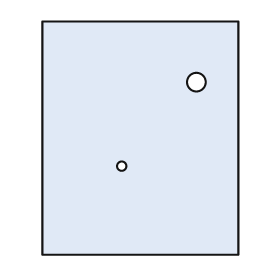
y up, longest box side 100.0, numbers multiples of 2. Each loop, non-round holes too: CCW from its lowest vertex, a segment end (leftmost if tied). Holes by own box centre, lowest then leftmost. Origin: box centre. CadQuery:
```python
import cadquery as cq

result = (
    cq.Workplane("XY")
    .moveTo(-42.0, -50.0)
    .lineTo(42.0, -50.0)
    .lineTo(42.0, 50.0)
    .lineTo(-42.0, 50.0)
    .close()
    .moveTo(-8.0, -12.0)
    .circle(2.0)
    .moveTo(24.0, 24.0)
    .circle(4.0)
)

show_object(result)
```